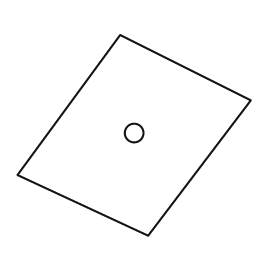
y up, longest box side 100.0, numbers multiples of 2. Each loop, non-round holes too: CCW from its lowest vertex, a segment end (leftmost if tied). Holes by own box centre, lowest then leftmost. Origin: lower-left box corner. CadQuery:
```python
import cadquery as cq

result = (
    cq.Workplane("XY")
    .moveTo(56.0, 0.0)
    .lineTo(100.0, 58.0)
    .lineTo(44.0, 86.0)
    .lineTo(0.0, 26.0)
    .close()
    .moveTo(50.0, 44.0)
    .circle(4.0)
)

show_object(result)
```